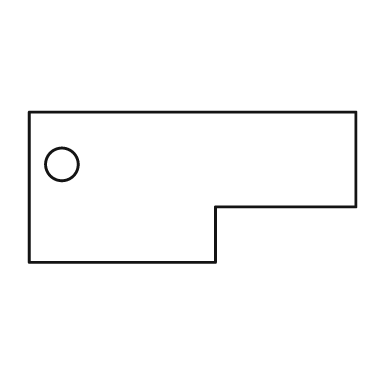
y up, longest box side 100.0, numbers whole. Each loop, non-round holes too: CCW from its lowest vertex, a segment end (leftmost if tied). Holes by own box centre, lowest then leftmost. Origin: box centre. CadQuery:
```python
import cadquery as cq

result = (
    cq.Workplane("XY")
    .moveTo(-50.0, -23.0)
    .lineTo(7.0, -23.0)
    .lineTo(7.0, -6.0)
    .lineTo(50.0, -6.0)
    .lineTo(50.0, 23.0)
    .lineTo(-50.0, 23.0)
    .close()
    .moveTo(-40.0, 7.0)
    .circle(5.0)
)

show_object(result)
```